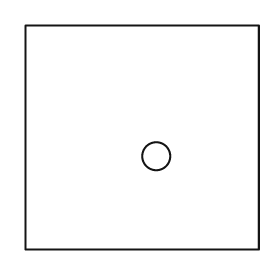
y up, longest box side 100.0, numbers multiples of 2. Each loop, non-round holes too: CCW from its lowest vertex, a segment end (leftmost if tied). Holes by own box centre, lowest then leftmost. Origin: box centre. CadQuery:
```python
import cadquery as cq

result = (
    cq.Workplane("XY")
    .moveTo(-50.0, -48.0)
    .lineTo(50.0, -48.0)
    .lineTo(50.0, 48.0)
    .lineTo(-50.0, 48.0)
    .close()
    .moveTo(6.0, -8.0)
    .circle(6.0)
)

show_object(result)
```